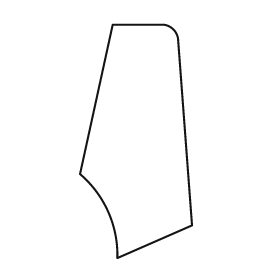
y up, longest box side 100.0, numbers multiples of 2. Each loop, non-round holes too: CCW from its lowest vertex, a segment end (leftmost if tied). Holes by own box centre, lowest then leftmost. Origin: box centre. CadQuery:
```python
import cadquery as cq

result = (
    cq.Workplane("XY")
    .moveTo(-8.0, -50.0)
    .lineTo(24.0, -36.0)
    .lineTo(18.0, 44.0)
    .threePointArc((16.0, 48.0), (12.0, 50.0))
    .lineTo(-10.0, 50.0)
    .lineTo(-24.0, -14.0)
    .threePointArc((-12.0, -30.0), (-8.0, -50.0))
    .close()
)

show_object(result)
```